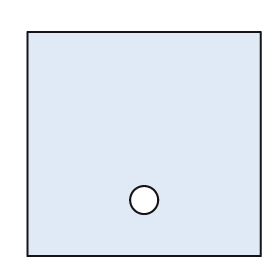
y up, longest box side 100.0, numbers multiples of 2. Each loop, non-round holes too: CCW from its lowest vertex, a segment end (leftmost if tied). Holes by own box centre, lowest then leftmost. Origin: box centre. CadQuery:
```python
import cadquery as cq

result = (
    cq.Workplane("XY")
    .moveTo(-50.0, -48.0)
    .lineTo(50.0, -48.0)
    .lineTo(50.0, 48.0)
    .lineTo(-50.0, 48.0)
    .close()
    .moveTo(0.0, -24.0)
    .circle(6.0)
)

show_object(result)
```